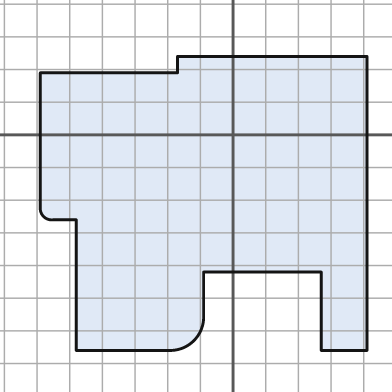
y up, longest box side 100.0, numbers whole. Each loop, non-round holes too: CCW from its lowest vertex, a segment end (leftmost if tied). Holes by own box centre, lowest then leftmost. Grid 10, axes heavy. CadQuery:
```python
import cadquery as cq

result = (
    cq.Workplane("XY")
    .moveTo(-48.0, -66.0)
    .lineTo(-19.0, -66.0)
    .threePointArc((-12.0, -63.0), (-9.0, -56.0))
    .lineTo(-9.0, -42.0)
    .lineTo(27.0, -42.0)
    .lineTo(27.0, -66.0)
    .lineTo(41.0, -66.0)
    .lineTo(41.0, 24.0)
    .lineTo(-17.0, 24.0)
    .lineTo(-17.0, 19.0)
    .lineTo(-59.0, 19.0)
    .lineTo(-59.0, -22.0)
    .threePointArc((-58.0, -25.0), (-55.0, -26.0))
    .lineTo(-48.0, -26.0)
    .close()
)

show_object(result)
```